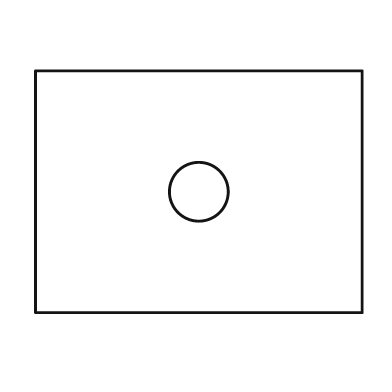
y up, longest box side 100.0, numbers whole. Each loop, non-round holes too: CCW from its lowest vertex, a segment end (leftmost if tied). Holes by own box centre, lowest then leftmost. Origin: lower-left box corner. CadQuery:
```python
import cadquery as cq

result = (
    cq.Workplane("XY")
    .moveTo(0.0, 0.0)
    .lineTo(100.0, 0.0)
    .lineTo(100.0, 74.0)
    .lineTo(0.0, 74.0)
    .close()
    .moveTo(50.0, 37.0)
    .circle(9.0)
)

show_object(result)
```